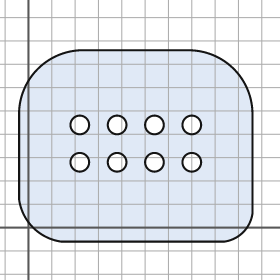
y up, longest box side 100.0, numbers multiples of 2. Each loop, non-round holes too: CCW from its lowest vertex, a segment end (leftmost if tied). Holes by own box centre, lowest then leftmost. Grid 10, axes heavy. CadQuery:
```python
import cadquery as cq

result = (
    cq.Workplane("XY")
    .moveTo(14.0, -6.0)
    .lineTo(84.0, -6.0)
    .threePointArc((92.0, -2.0), (96.0, 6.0))
    .lineTo(96.0, 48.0)
    .threePointArc((88.0, 68.0), (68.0, 76.0))
    .lineTo(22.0, 76.0)
    .threePointArc((4.0, 68.0), (-4.0, 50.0))
    .lineTo(-4.0, 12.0)
    .threePointArc((2.0, 0.0), (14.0, -6.0))
    .close()
    .moveTo(22.0, 28.0)
    .circle(4.0)
    .moveTo(38.0, 28.0)
    .circle(4.0)
    .moveTo(54.0, 28.0)
    .circle(4.0)
    .moveTo(70.0, 28.0)
    .circle(4.0)
    .moveTo(22.0, 44.0)
    .circle(4.0)
    .moveTo(38.0, 44.0)
    .circle(4.0)
    .moveTo(54.0, 44.0)
    .circle(4.0)
    .moveTo(70.0, 44.0)
    .circle(4.0)
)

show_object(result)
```